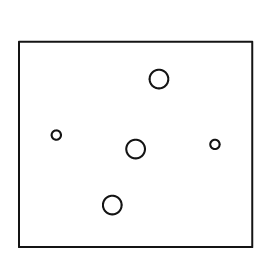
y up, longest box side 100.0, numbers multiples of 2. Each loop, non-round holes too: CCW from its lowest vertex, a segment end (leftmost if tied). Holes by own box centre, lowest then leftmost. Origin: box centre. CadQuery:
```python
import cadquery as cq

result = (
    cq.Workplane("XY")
    .moveTo(-50.0, -44.0)
    .lineTo(50.0, -44.0)
    .lineTo(50.0, 44.0)
    .lineTo(-50.0, 44.0)
    .close()
    .moveTo(-10.0, -26.0)
    .circle(4.0)
    .moveTo(0.0, -2.0)
    .circle(4.0)
    .moveTo(34.0, 0.0)
    .circle(2.0)
    .moveTo(-34.0, 4.0)
    .circle(2.0)
    .moveTo(10.0, 28.0)
    .circle(4.0)
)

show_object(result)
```